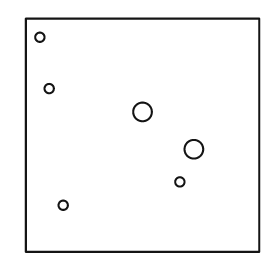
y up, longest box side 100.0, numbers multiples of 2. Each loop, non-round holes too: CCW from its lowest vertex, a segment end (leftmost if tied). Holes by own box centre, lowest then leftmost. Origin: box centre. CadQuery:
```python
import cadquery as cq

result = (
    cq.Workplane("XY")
    .moveTo(-50.0, -50.0)
    .lineTo(50.0, -50.0)
    .lineTo(50.0, 50.0)
    .lineTo(-50.0, 50.0)
    .close()
    .moveTo(-34.0, -30.0)
    .circle(2.0)
    .moveTo(16.0, -20.0)
    .circle(2.0)
    .moveTo(22.0, -6.0)
    .circle(4.0)
    .moveTo(0.0, 10.0)
    .circle(4.0)
    .moveTo(-40.0, 20.0)
    .circle(2.0)
    .moveTo(-44.0, 42.0)
    .circle(2.0)
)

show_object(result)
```